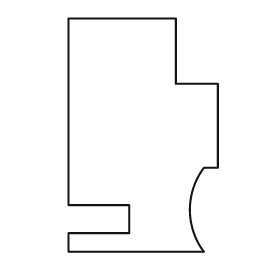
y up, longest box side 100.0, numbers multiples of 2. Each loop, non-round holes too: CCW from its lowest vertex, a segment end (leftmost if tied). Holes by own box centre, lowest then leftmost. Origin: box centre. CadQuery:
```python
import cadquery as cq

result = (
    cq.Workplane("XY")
    .moveTo(-32.0, -50.0)
    .lineTo(26.0, -50.0)
    .threePointArc((20.0, -32.0), (26.0, -14.0))
    .lineTo(32.0, -14.0)
    .lineTo(32.0, 22.0)
    .lineTo(14.0, 22.0)
    .lineTo(14.0, 50.0)
    .lineTo(-32.0, 50.0)
    .lineTo(-32.0, -30.0)
    .lineTo(-6.0, -30.0)
    .lineTo(-6.0, -42.0)
    .lineTo(-32.0, -42.0)
    .close()
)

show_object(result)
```